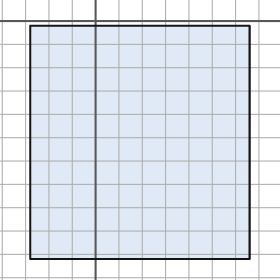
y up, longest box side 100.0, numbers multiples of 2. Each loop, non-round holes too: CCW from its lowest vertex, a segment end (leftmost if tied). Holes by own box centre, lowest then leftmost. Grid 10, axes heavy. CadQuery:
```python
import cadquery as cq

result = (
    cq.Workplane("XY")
    .moveTo(-28.0, -102.0)
    .lineTo(66.0, -102.0)
    .lineTo(66.0, -2.0)
    .lineTo(-28.0, -2.0)
    .close()
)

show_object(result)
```